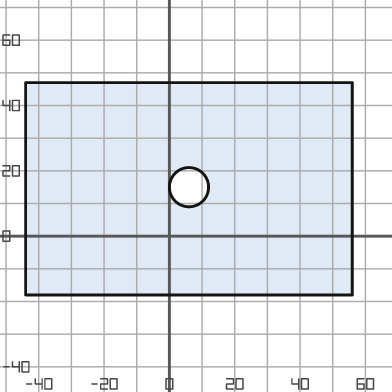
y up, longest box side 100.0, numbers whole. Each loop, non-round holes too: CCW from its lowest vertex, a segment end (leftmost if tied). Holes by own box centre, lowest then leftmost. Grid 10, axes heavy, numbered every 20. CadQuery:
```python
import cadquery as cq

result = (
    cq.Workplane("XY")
    .moveTo(-44.0, -18.0)
    .lineTo(56.0, -18.0)
    .lineTo(56.0, 47.0)
    .lineTo(-44.0, 47.0)
    .close()
    .moveTo(6.0, 15.0)
    .circle(6.0)
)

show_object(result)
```